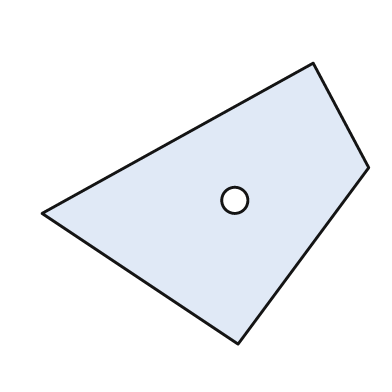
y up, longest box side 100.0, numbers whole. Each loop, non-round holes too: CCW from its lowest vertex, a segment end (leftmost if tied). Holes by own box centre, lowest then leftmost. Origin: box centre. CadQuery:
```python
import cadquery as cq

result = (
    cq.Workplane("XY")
    .moveTo(10.0, -43.0)
    .lineTo(50.0, 11.0)
    .lineTo(33.0, 43.0)
    .lineTo(-50.0, -3.0)
    .close()
    .moveTo(9.0, 1.0)
    .circle(4.0)
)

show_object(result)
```